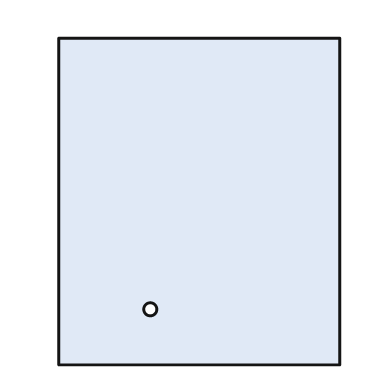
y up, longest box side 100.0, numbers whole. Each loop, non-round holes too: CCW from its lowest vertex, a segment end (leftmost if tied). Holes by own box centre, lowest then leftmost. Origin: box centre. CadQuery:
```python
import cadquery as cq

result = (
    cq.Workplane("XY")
    .moveTo(-43.0, -50.0)
    .lineTo(43.0, -50.0)
    .lineTo(43.0, 50.0)
    .lineTo(-43.0, 50.0)
    .close()
    .moveTo(-15.0, -33.0)
    .circle(2.0)
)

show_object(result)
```